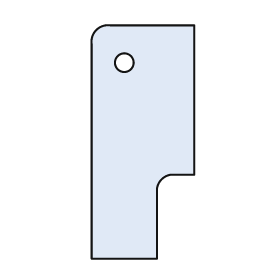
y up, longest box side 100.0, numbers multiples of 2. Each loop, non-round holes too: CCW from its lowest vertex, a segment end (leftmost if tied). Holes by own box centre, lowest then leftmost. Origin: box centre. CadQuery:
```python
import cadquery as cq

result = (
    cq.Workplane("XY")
    .moveTo(-22.0, -50.0)
    .lineTo(6.0, -50.0)
    .lineTo(6.0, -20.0)
    .threePointArc((8.0, -16.0), (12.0, -14.0))
    .lineTo(22.0, -14.0)
    .lineTo(22.0, 50.0)
    .lineTo(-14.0, 50.0)
    .threePointArc((-20.0, 48.0), (-22.0, 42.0))
    .close()
    .moveTo(-8.0, 34.0)
    .circle(4.0)
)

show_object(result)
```